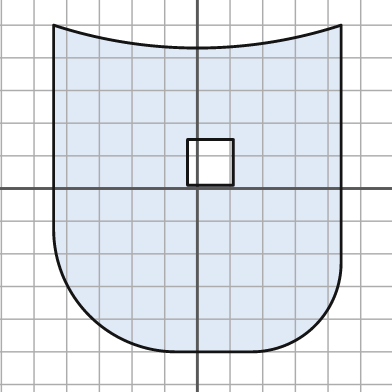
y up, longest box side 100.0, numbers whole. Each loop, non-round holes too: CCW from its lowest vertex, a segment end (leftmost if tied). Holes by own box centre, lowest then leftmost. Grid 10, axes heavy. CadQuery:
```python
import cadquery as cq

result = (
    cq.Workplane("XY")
    .moveTo(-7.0, -50.0)
    .lineTo(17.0, -50.0)
    .threePointArc((36.0, -42.0), (44.0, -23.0))
    .lineTo(44.0, 50.0)
    .threePointArc((0.0, 43.0), (-44.0, 50.0))
    .lineTo(-44.0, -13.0)
    .threePointArc((-33.0, -39.0), (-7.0, -50.0))
    .close()
    .moveTo(-3.0, 1.0)
    .lineTo(11.0, 1.0)
    .lineTo(11.0, 15.0)
    .lineTo(-3.0, 15.0)
    .close()
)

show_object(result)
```